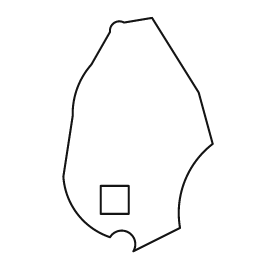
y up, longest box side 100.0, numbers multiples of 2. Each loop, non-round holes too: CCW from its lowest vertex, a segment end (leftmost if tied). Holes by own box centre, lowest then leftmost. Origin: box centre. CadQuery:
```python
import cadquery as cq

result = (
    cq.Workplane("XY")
    .moveTo(-2.0, -50.0)
    .lineTo(18.0, -40.0)
    .threePointArc((20.0, -20.0), (32.0, -4.0))
    .lineTo(26.0, 18.0)
    .lineTo(6.0, 50.0)
    .lineTo(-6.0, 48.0)
    .threePointArc((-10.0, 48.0), (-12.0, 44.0))
    .lineTo(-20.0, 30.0)
    .threePointArc((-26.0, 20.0), (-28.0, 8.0))
    .lineTo(-32.0, -18.0)
    .threePointArc((-26.0, -34.0), (-12.0, -44.0))
    .threePointArc((-4.0, -42.0), (-2.0, -50.0))
    .close()
    .moveTo(-16.0, -34.0)
    .lineTo(-4.0, -34.0)
    .lineTo(-4.0, -22.0)
    .lineTo(-16.0, -22.0)
    .close()
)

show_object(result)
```